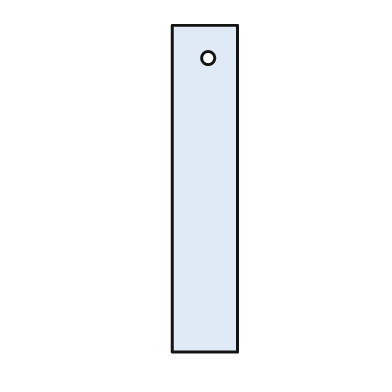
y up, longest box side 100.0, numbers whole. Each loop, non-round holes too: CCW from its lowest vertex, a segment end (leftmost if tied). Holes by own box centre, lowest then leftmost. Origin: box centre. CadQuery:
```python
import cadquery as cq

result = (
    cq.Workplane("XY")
    .moveTo(-10.0, -50.0)
    .lineTo(10.0, -50.0)
    .lineTo(10.0, 50.0)
    .lineTo(-10.0, 50.0)
    .close()
    .moveTo(1.0, 40.0)
    .circle(2.0)
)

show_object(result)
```